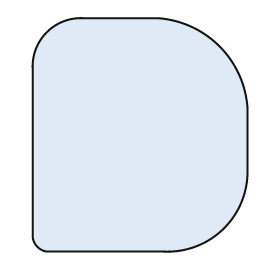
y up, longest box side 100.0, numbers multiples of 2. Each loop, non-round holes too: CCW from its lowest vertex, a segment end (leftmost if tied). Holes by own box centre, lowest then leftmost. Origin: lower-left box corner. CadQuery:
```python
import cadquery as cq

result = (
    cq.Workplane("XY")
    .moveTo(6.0, 0.0)
    .lineTo(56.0, 0.0)
    .threePointArc((82.0, 10.0), (92.0, 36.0))
    .lineTo(92.0, 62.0)
    .threePointArc((80.0, 88.0), (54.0, 100.0))
    .lineTo(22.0, 100.0)
    .threePointArc((6.0, 94.0), (0.0, 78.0))
    .lineTo(0.0, 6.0)
    .threePointArc((2.0, 2.0), (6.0, 0.0))
    .close()
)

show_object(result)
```